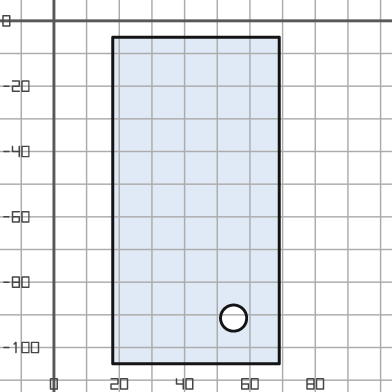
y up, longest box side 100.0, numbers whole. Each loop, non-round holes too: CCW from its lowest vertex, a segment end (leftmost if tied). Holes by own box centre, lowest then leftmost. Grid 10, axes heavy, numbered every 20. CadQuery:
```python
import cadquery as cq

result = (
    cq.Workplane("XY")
    .moveTo(18.0, -105.0)
    .lineTo(69.0, -105.0)
    .lineTo(69.0, -5.0)
    .lineTo(18.0, -5.0)
    .close()
    .moveTo(55.0, -91.0)
    .circle(4.0)
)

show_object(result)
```